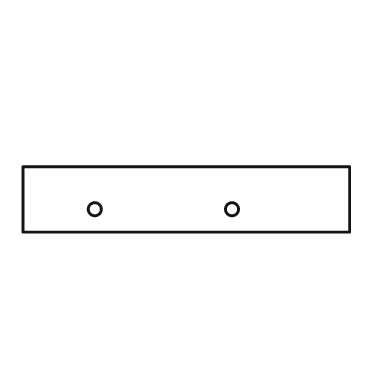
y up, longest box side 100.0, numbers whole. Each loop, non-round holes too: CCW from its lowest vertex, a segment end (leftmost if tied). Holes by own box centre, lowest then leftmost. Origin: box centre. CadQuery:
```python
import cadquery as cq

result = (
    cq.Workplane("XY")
    .moveTo(-50.0, -10.0)
    .lineTo(50.0, -10.0)
    .lineTo(50.0, 10.0)
    .lineTo(-50.0, 10.0)
    .close()
    .moveTo(-28.0, -3.0)
    .circle(2.0)
    .moveTo(14.0, -3.0)
    .circle(2.0)
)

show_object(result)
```